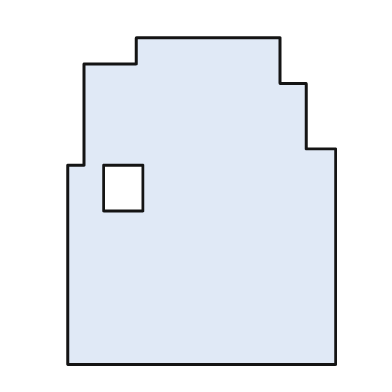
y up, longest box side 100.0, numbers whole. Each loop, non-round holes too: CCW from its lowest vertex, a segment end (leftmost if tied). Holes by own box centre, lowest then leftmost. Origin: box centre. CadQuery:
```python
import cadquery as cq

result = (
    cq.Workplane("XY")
    .moveTo(-41.0, -50.0)
    .lineTo(41.0, -50.0)
    .lineTo(41.0, 16.0)
    .lineTo(32.0, 16.0)
    .lineTo(32.0, 36.0)
    .lineTo(24.0, 36.0)
    .lineTo(24.0, 50.0)
    .lineTo(-20.0, 50.0)
    .lineTo(-20.0, 42.0)
    .lineTo(-36.0, 42.0)
    .lineTo(-36.0, 11.0)
    .lineTo(-41.0, 11.0)
    .close()
    .moveTo(-30.0, -3.0)
    .lineTo(-18.0, -3.0)
    .lineTo(-18.0, 11.0)
    .lineTo(-30.0, 11.0)
    .close()
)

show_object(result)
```